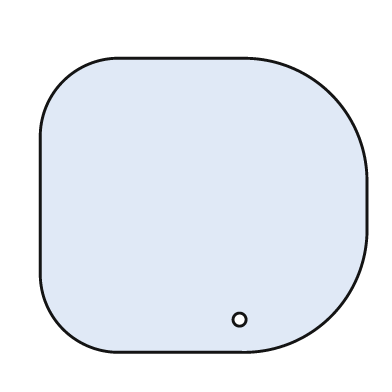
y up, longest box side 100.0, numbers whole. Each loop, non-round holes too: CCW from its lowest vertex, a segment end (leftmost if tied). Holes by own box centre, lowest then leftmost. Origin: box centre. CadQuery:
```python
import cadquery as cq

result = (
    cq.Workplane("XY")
    .moveTo(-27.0, -45.0)
    .lineTo(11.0, -45.0)
    .threePointArc((39.0, -34.0), (50.0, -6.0))
    .lineTo(50.0, 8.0)
    .threePointArc((39.0, 34.0), (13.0, 45.0))
    .lineTo(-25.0, 45.0)
    .threePointArc((-43.0, 38.0), (-50.0, 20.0))
    .lineTo(-50.0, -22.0)
    .threePointArc((-43.0, -38.0), (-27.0, -45.0))
    .close()
    .moveTo(11.0, -35.0)
    .circle(2.0)
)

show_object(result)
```